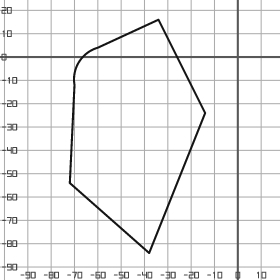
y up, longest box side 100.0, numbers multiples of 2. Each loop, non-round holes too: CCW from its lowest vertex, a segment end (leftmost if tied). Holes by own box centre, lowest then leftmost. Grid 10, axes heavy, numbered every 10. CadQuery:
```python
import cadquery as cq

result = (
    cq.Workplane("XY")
    .moveTo(-38.0, -84.0)
    .lineTo(-14.0, -24.0)
    .lineTo(-34.0, 16.0)
    .lineTo(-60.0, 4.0)
    .threePointArc((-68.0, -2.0), (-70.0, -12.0))
    .lineTo(-72.0, -54.0)
    .close()
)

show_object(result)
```